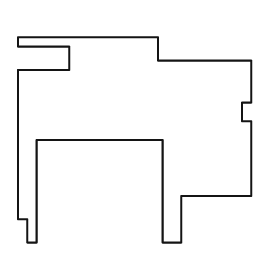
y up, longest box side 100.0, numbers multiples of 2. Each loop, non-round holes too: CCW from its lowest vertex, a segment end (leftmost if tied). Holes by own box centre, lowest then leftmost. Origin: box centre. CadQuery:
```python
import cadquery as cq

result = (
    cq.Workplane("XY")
    .moveTo(-46.0, -44.0)
    .lineTo(-42.0, -44.0)
    .lineTo(-42.0, 0.0)
    .lineTo(12.0, 0.0)
    .lineTo(12.0, -44.0)
    .lineTo(20.0, -44.0)
    .lineTo(20.0, -24.0)
    .lineTo(50.0, -24.0)
    .lineTo(50.0, 8.0)
    .lineTo(46.0, 8.0)
    .lineTo(46.0, 16.0)
    .lineTo(50.0, 16.0)
    .lineTo(50.0, 34.0)
    .lineTo(10.0, 34.0)
    .lineTo(10.0, 44.0)
    .lineTo(-50.0, 44.0)
    .lineTo(-50.0, 40.0)
    .lineTo(-28.0, 40.0)
    .lineTo(-28.0, 30.0)
    .lineTo(-50.0, 30.0)
    .lineTo(-50.0, -34.0)
    .lineTo(-46.0, -34.0)
    .close()
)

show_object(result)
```